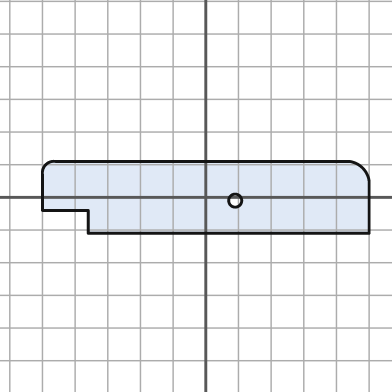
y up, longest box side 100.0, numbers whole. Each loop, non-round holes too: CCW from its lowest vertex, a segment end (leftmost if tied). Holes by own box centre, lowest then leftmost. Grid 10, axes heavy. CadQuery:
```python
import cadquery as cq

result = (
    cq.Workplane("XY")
    .moveTo(-36.0, -11.0)
    .lineTo(50.0, -11.0)
    .lineTo(50.0, 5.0)
    .threePointArc((48.0, 9.0), (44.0, 11.0))
    .lineTo(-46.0, 11.0)
    .threePointArc((-49.0, 10.0), (-50.0, 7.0))
    .lineTo(-50.0, -4.0)
    .lineTo(-36.0, -4.0)
    .close()
    .moveTo(9.0, -1.0)
    .circle(2.0)
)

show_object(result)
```